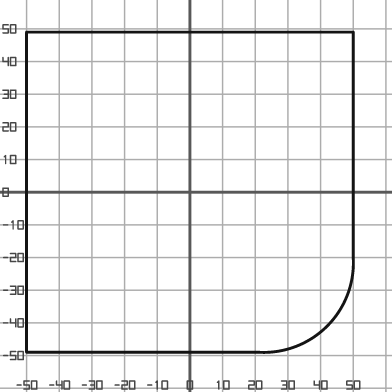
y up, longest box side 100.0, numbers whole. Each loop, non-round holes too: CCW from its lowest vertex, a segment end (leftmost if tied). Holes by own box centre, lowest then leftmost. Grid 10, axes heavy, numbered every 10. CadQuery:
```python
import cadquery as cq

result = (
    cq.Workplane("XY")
    .moveTo(-50.0, -49.0)
    .lineTo(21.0, -49.0)
    .threePointArc((42.0, -41.0), (50.0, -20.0))
    .lineTo(50.0, 49.0)
    .lineTo(-50.0, 49.0)
    .close()
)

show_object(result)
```